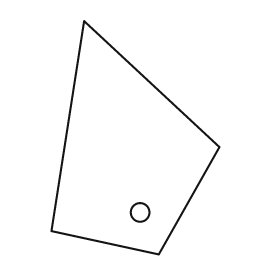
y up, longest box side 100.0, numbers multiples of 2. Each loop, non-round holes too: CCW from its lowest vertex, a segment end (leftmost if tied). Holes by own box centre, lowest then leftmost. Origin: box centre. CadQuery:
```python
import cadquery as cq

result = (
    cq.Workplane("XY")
    .moveTo(10.0, -50.0)
    .lineTo(36.0, -4.0)
    .lineTo(-22.0, 50.0)
    .lineTo(-36.0, -40.0)
    .close()
    .moveTo(2.0, -32.0)
    .circle(4.0)
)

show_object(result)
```